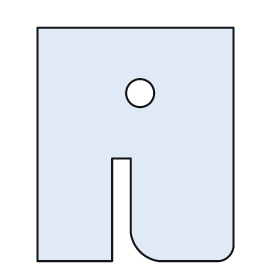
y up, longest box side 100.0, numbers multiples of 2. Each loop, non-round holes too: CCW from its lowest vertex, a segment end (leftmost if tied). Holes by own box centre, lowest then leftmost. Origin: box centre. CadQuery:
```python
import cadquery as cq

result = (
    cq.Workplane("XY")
    .moveTo(-42.0, -50.0)
    .lineTo(-10.0, -50.0)
    .lineTo(-10.0, -6.0)
    .lineTo(-2.0, -6.0)
    .lineTo(-2.0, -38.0)
    .threePointArc((2.0, -46.0), (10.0, -50.0))
    .lineTo(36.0, -50.0)
    .threePointArc((40.0, -48.0), (42.0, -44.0))
    .lineTo(42.0, 50.0)
    .lineTo(-42.0, 50.0)
    .close()
    .moveTo(2.0, 22.0)
    .circle(6.0)
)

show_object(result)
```